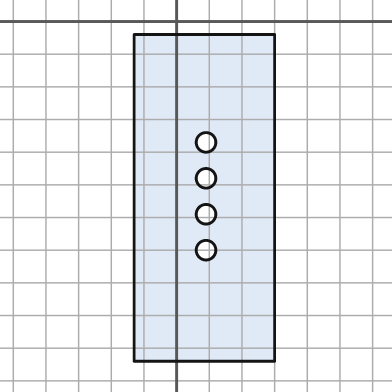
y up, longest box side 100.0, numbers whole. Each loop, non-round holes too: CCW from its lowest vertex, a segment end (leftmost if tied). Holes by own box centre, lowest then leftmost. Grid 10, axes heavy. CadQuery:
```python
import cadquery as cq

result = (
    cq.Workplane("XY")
    .moveTo(-13.0, -104.0)
    .lineTo(30.0, -104.0)
    .lineTo(30.0, -4.0)
    .lineTo(-13.0, -4.0)
    .close()
    .moveTo(9.0, -70.0)
    .circle(3.0)
    .moveTo(9.0, -59.0)
    .circle(3.0)
    .moveTo(9.0, -48.0)
    .circle(3.0)
    .moveTo(9.0, -37.0)
    .circle(3.0)
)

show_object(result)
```